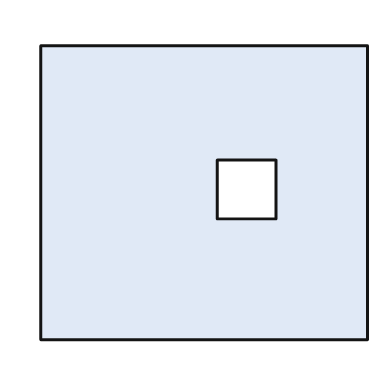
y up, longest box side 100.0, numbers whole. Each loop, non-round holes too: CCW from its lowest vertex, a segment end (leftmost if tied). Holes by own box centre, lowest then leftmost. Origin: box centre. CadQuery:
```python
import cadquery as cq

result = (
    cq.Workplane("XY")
    .moveTo(-50.0, -45.0)
    .lineTo(50.0, -45.0)
    .lineTo(50.0, 45.0)
    .lineTo(-50.0, 45.0)
    .close()
    .moveTo(4.0, -8.0)
    .lineTo(22.0, -8.0)
    .lineTo(22.0, 10.0)
    .lineTo(4.0, 10.0)
    .close()
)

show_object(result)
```